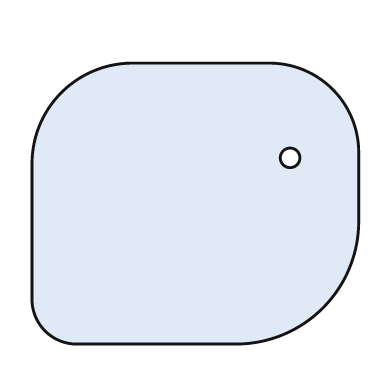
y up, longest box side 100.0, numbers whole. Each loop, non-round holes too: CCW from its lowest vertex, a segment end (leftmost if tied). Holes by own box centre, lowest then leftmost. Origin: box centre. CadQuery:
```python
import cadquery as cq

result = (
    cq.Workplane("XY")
    .moveTo(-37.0, -43.0)
    .lineTo(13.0, -43.0)
    .threePointArc((39.0, -32.0), (50.0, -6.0))
    .lineTo(50.0, 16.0)
    .threePointArc((42.0, 35.0), (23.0, 43.0))
    .lineTo(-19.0, 43.0)
    .threePointArc((-41.0, 34.0), (-50.0, 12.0))
    .lineTo(-50.0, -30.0)
    .threePointArc((-46.0, -39.0), (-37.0, -43.0))
    .close()
    .moveTo(29.0, 14.0)
    .circle(3.0)
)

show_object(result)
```